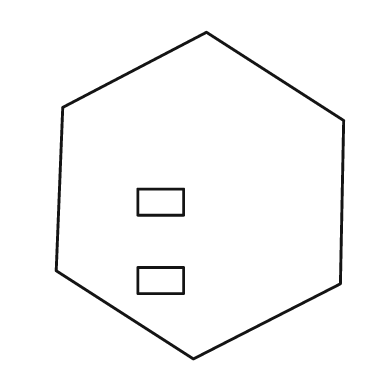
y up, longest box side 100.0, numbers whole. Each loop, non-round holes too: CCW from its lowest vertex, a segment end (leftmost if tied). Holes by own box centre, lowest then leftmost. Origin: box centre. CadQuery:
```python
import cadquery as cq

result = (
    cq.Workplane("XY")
    .moveTo(-2.0, -50.0)
    .lineTo(43.0, -27.0)
    .lineTo(44.0, 23.0)
    .lineTo(2.0, 50.0)
    .lineTo(-42.0, 27.0)
    .lineTo(-44.0, -23.0)
    .close()
    .moveTo(-19.0, -30.0)
    .lineTo(-5.0, -30.0)
    .lineTo(-5.0, -22.0)
    .lineTo(-19.0, -22.0)
    .close()
    .moveTo(-19.0, -6.0)
    .lineTo(-5.0, -6.0)
    .lineTo(-5.0, 2.0)
    .lineTo(-19.0, 2.0)
    .close()
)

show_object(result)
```